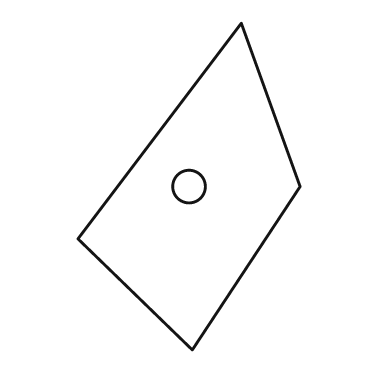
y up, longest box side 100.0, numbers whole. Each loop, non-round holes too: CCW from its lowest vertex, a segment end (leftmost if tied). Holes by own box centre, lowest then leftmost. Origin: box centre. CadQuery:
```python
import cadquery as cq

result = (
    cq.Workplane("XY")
    .moveTo(1.0, -50.0)
    .lineTo(34.0, 0.0)
    .lineTo(16.0, 50.0)
    .lineTo(-34.0, -16.0)
    .close()
    .moveTo(0.0, 0.0)
    .circle(5.0)
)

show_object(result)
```